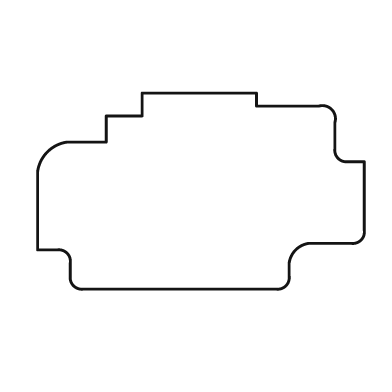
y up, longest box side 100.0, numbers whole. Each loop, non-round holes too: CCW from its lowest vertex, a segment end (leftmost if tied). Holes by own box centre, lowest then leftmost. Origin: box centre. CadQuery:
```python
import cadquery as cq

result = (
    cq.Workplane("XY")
    .moveTo(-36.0, -30.0)
    .lineTo(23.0, -30.0)
    .threePointArc((26.0, -29.0), (27.0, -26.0))
    .lineTo(27.0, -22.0)
    .threePointArc((29.0, -18.0), (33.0, -16.0))
    .lineTo(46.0, -16.0)
    .threePointArc((49.0, -15.0), (50.0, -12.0))
    .lineTo(50.0, 9.0)
    .lineTo(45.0, 9.0)
    .threePointArc((42.0, 10.0), (41.0, 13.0))
    .lineTo(41.0, 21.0)
    .threePointArc((40.0, 25.0), (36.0, 26.0))
    .lineTo(17.0, 26.0)
    .lineTo(17.0, 30.0)
    .lineTo(-18.0, 30.0)
    .lineTo(-18.0, 23.0)
    .lineTo(-29.0, 23.0)
    .lineTo(-29.0, 15.0)
    .lineTo(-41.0, 15.0)
    .threePointArc((-47.0, 12.0), (-50.0, 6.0))
    .lineTo(-50.0, -18.0)
    .lineTo(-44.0, -18.0)
    .threePointArc((-41.0, -19.0), (-40.0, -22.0))
    .lineTo(-40.0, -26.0)
    .threePointArc((-39.0, -29.0), (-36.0, -30.0))
    .close()
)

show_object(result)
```